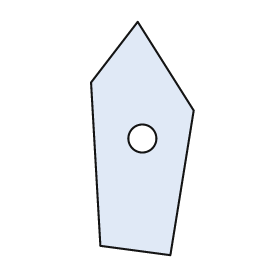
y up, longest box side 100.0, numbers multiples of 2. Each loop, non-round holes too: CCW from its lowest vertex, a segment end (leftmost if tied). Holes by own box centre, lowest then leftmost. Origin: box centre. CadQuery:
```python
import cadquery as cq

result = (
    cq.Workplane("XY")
    .moveTo(12.0, -50.0)
    .lineTo(22.0, 12.0)
    .lineTo(-2.0, 50.0)
    .lineTo(-22.0, 24.0)
    .lineTo(-18.0, -46.0)
    .close()
    .moveTo(0.0, 0.0)
    .circle(6.0)
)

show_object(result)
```